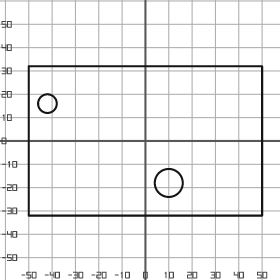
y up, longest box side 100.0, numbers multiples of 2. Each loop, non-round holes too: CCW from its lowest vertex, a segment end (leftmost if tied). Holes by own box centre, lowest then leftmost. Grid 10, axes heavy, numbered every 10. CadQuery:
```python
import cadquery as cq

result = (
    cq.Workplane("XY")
    .moveTo(-50.0, -32.0)
    .lineTo(50.0, -32.0)
    .lineTo(50.0, 32.0)
    .lineTo(-50.0, 32.0)
    .close()
    .moveTo(10.0, -18.0)
    .circle(6.0)
    .moveTo(-42.0, 16.0)
    .circle(4.0)
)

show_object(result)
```